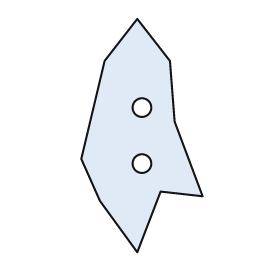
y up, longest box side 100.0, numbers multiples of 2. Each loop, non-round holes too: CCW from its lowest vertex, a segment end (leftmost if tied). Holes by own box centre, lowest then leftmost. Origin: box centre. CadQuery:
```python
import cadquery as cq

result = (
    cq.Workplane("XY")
    .moveTo(-2.0, -50.0)
    .lineTo(8.0, -24.0)
    .lineTo(26.0, -26.0)
    .lineTo(14.0, 6.0)
    .lineTo(12.0, 32.0)
    .lineTo(-2.0, 50.0)
    .lineTo(-16.0, 32.0)
    .lineTo(-26.0, -10.0)
    .lineTo(-18.0, -28.0)
    .close()
    .moveTo(0.0, -12.0)
    .circle(4.0)
    .moveTo(0.0, 12.0)
    .circle(4.0)
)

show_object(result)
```